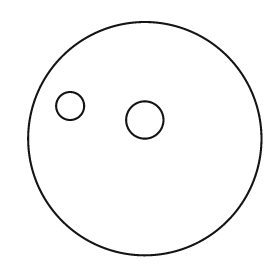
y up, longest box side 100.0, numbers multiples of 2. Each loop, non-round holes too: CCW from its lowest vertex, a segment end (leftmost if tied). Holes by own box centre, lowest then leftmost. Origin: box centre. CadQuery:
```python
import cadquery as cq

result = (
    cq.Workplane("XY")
    .moveTo(0.0, 0.0)
    .circle(50.0)
    .moveTo(0.0, 8.0)
    .circle(8.0)
    .moveTo(-32.0, 14.0)
    .circle(6.0)
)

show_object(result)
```